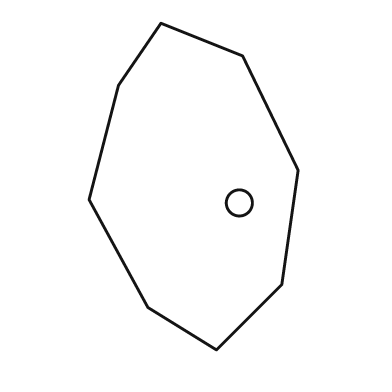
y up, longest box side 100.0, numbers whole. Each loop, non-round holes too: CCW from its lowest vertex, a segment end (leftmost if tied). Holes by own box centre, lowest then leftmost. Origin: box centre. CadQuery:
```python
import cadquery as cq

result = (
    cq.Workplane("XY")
    .moveTo(7.0, -50.0)
    .lineTo(27.0, -30.0)
    .lineTo(32.0, 5.0)
    .lineTo(15.0, 40.0)
    .lineTo(-10.0, 50.0)
    .lineTo(-23.0, 31.0)
    .lineTo(-32.0, -4.0)
    .lineTo(-14.0, -37.0)
    .close()
    .moveTo(14.0, -5.0)
    .circle(4.0)
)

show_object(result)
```